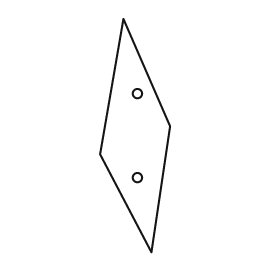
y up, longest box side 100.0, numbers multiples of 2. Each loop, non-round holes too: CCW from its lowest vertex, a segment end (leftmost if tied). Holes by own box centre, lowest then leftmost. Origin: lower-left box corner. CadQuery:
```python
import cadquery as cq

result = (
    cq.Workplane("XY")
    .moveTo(22.0, 0.0)
    .lineTo(30.0, 54.0)
    .lineTo(10.0, 100.0)
    .lineTo(0.0, 42.0)
    .close()
    .moveTo(16.0, 32.0)
    .circle(2.0)
    .moveTo(16.0, 68.0)
    .circle(2.0)
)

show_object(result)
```